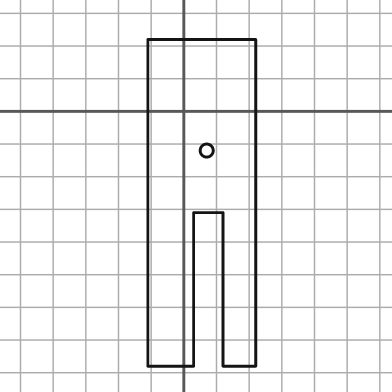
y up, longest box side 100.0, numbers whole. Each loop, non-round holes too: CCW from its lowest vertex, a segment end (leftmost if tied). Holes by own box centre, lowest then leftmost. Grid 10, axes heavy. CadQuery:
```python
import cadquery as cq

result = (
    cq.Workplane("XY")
    .moveTo(-11.0, -78.0)
    .lineTo(3.0, -78.0)
    .lineTo(3.0, -31.0)
    .lineTo(12.0, -31.0)
    .lineTo(12.0, -78.0)
    .lineTo(22.0, -78.0)
    .lineTo(22.0, 22.0)
    .lineTo(-11.0, 22.0)
    .close()
    .moveTo(7.0, -12.0)
    .circle(2.0)
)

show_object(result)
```